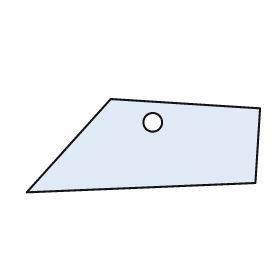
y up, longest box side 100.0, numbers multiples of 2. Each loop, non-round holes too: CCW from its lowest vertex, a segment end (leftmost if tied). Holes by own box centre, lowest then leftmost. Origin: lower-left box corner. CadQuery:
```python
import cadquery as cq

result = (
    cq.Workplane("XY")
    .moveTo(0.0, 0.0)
    .lineTo(98.0, 4.0)
    .lineTo(100.0, 36.0)
    .lineTo(36.0, 40.0)
    .close()
    .moveTo(54.0, 30.0)
    .circle(4.0)
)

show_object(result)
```